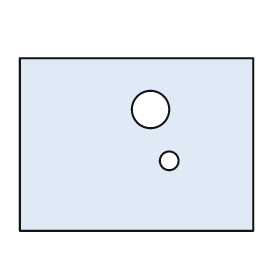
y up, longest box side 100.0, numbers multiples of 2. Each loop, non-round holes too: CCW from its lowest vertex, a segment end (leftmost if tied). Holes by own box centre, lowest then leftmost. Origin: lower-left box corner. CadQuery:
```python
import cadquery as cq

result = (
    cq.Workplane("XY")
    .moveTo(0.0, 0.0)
    .lineTo(100.0, 0.0)
    .lineTo(100.0, 74.0)
    .lineTo(0.0, 74.0)
    .close()
    .moveTo(64.0, 30.0)
    .circle(4.0)
    .moveTo(56.0, 52.0)
    .circle(8.0)
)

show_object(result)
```